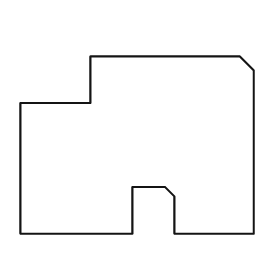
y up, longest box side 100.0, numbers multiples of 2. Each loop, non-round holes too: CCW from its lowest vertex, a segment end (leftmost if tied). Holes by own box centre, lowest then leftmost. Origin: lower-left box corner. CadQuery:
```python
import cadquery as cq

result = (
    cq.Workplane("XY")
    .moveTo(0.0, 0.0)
    .lineTo(48.0, 0.0)
    .lineTo(48.0, 20.0)
    .lineTo(62.0, 20.0)
    .lineTo(66.0, 16.0)
    .lineTo(66.0, 0.0)
    .lineTo(100.0, 0.0)
    .lineTo(100.0, 70.0)
    .lineTo(94.0, 76.0)
    .lineTo(30.0, 76.0)
    .lineTo(30.0, 56.0)
    .lineTo(0.0, 56.0)
    .close()
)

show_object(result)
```